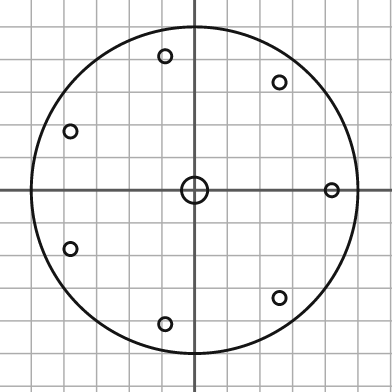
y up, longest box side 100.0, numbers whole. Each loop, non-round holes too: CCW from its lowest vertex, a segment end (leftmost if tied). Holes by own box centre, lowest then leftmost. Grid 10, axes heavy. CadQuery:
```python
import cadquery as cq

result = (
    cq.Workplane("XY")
    .moveTo(0.0, 0.0)
    .circle(50.0)
    .moveTo(-9.0, -41.0)
    .circle(2.0)
    .moveTo(26.0, -33.0)
    .circle(2.0)
    .moveTo(-38.0, -18.0)
    .circle(2.0)
    .moveTo(0.0, 0.0)
    .circle(4.0)
    .moveTo(42.0, 0.0)
    .circle(2.0)
    .moveTo(-38.0, 18.0)
    .circle(2.0)
    .moveTo(26.0, 33.0)
    .circle(2.0)
    .moveTo(-9.0, 41.0)
    .circle(2.0)
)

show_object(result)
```